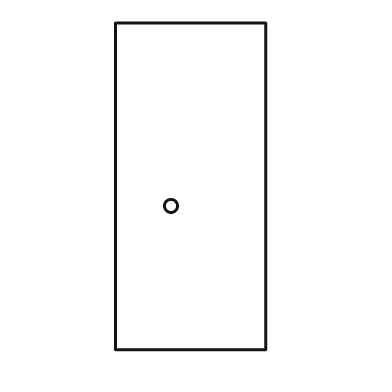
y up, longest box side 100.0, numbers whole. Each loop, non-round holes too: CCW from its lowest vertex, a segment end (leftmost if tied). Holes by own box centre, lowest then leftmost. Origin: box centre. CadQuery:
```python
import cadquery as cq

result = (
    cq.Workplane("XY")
    .moveTo(-23.0, -50.0)
    .lineTo(23.0, -50.0)
    .lineTo(23.0, 50.0)
    .lineTo(-23.0, 50.0)
    .close()
    .moveTo(-6.0, -6.0)
    .circle(2.0)
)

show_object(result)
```